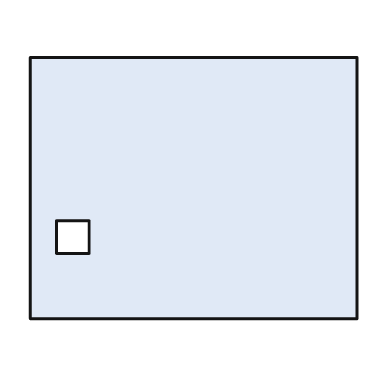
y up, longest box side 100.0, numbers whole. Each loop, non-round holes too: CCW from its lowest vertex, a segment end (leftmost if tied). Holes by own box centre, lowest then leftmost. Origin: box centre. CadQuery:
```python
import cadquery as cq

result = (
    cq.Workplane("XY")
    .moveTo(-50.0, -40.0)
    .lineTo(50.0, -40.0)
    .lineTo(50.0, 40.0)
    .lineTo(-50.0, 40.0)
    .close()
    .moveTo(-42.0, -20.0)
    .lineTo(-32.0, -20.0)
    .lineTo(-32.0, -10.0)
    .lineTo(-42.0, -10.0)
    .close()
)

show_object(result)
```